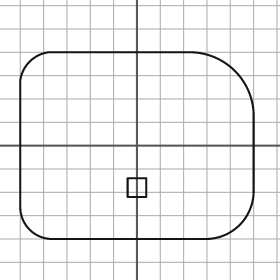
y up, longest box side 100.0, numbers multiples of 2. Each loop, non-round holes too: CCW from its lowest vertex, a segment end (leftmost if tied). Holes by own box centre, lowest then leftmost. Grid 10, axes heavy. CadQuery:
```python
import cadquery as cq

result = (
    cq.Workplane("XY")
    .moveTo(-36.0, -40.0)
    .lineTo(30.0, -40.0)
    .threePointArc((44.0, -34.0), (50.0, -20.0))
    .lineTo(50.0, 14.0)
    .threePointArc((42.0, 32.0), (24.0, 40.0))
    .lineTo(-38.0, 40.0)
    .threePointArc((-46.0, 36.0), (-50.0, 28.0))
    .lineTo(-50.0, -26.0)
    .threePointArc((-46.0, -36.0), (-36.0, -40.0))
    .close()
    .moveTo(-4.0, -22.0)
    .lineTo(4.0, -22.0)
    .lineTo(4.0, -14.0)
    .lineTo(-4.0, -14.0)
    .close()
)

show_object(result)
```